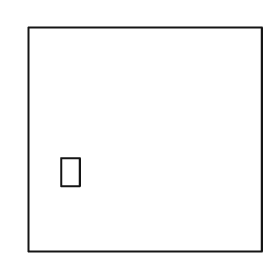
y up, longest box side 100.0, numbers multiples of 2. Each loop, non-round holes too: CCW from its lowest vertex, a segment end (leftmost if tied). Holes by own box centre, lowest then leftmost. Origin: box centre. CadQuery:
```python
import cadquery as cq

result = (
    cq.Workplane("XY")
    .moveTo(-50.0, -48.0)
    .lineTo(50.0, -48.0)
    .lineTo(50.0, 48.0)
    .lineTo(-50.0, 48.0)
    .close()
    .moveTo(-36.0, -20.0)
    .lineTo(-28.0, -20.0)
    .lineTo(-28.0, -8.0)
    .lineTo(-36.0, -8.0)
    .close()
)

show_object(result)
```